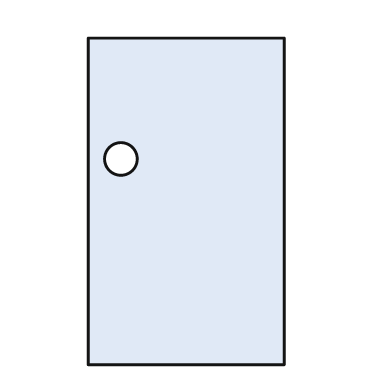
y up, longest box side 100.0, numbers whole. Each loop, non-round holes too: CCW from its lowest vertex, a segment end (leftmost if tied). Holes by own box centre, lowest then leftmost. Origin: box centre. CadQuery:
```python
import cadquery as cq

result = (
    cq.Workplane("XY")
    .moveTo(-30.0, -50.0)
    .lineTo(30.0, -50.0)
    .lineTo(30.0, 50.0)
    .lineTo(-30.0, 50.0)
    .close()
    .moveTo(-20.0, 13.0)
    .circle(5.0)
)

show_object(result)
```